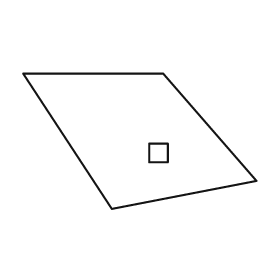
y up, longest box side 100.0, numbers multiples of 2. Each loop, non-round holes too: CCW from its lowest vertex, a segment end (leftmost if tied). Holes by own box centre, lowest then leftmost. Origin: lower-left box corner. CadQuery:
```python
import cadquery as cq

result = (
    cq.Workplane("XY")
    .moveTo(38.0, 0.0)
    .lineTo(100.0, 12.0)
    .lineTo(60.0, 58.0)
    .lineTo(0.0, 58.0)
    .close()
    .moveTo(54.0, 20.0)
    .lineTo(62.0, 20.0)
    .lineTo(62.0, 28.0)
    .lineTo(54.0, 28.0)
    .close()
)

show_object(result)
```